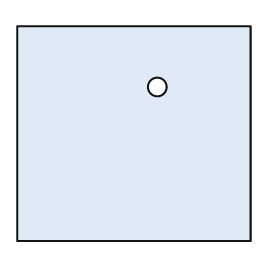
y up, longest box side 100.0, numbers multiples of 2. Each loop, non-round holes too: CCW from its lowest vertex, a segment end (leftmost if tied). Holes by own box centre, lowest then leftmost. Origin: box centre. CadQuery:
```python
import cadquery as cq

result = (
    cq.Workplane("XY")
    .moveTo(-50.0, -46.0)
    .lineTo(50.0, -46.0)
    .lineTo(50.0, 46.0)
    .lineTo(-50.0, 46.0)
    .close()
    .moveTo(10.0, 20.0)
    .circle(4.0)
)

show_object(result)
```